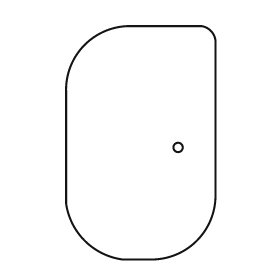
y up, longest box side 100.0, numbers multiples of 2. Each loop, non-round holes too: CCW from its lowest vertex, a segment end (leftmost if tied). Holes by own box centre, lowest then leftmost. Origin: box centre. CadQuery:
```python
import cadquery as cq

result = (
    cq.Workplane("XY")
    .moveTo(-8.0, -50.0)
    .lineTo(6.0, -50.0)
    .threePointArc((24.0, -42.0), (32.0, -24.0))
    .lineTo(32.0, 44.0)
    .threePointArc((30.0, 48.0), (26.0, 50.0))
    .lineTo(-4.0, 50.0)
    .threePointArc((-24.0, 42.0), (-32.0, 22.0))
    .lineTo(-32.0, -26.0)
    .threePointArc((-24.0, -42.0), (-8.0, -50.0))
    .close()
    .moveTo(16.0, -2.0)
    .circle(2.0)
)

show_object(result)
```